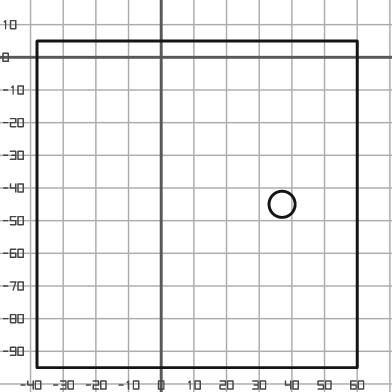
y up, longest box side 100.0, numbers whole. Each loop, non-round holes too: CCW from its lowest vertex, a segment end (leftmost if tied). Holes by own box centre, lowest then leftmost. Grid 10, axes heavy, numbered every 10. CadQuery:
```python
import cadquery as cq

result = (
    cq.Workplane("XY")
    .moveTo(-38.0, -95.0)
    .lineTo(60.0, -95.0)
    .lineTo(60.0, 5.0)
    .lineTo(-38.0, 5.0)
    .close()
    .moveTo(37.0, -45.0)
    .circle(4.0)
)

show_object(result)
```